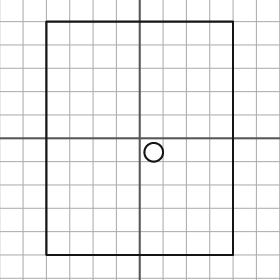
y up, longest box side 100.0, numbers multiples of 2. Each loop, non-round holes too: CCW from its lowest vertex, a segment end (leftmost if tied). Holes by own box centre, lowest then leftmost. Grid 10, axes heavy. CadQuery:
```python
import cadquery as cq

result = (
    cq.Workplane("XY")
    .moveTo(-40.0, -50.0)
    .lineTo(40.0, -50.0)
    .lineTo(40.0, 50.0)
    .lineTo(-40.0, 50.0)
    .close()
    .moveTo(6.0, -6.0)
    .circle(4.0)
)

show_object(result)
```